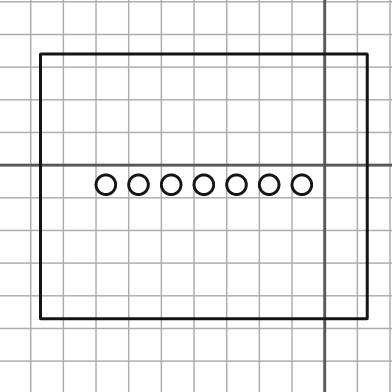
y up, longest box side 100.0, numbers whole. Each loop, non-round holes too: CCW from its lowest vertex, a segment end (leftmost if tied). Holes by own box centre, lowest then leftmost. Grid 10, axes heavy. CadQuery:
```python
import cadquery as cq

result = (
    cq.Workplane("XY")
    .moveTo(-87.0, -47.0)
    .lineTo(13.0, -47.0)
    .lineTo(13.0, 34.0)
    .lineTo(-87.0, 34.0)
    .close()
    .moveTo(-67.0, -6.0)
    .circle(3.0)
    .moveTo(-57.0, -6.0)
    .circle(3.0)
    .moveTo(-47.0, -6.0)
    .circle(3.0)
    .moveTo(-37.0, -6.0)
    .circle(3.0)
    .moveTo(-27.0, -6.0)
    .circle(3.0)
    .moveTo(-17.0, -6.0)
    .circle(3.0)
    .moveTo(-7.0, -6.0)
    .circle(3.0)
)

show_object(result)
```